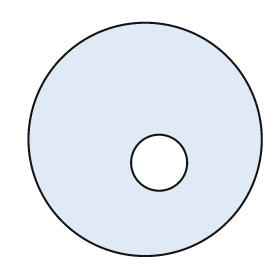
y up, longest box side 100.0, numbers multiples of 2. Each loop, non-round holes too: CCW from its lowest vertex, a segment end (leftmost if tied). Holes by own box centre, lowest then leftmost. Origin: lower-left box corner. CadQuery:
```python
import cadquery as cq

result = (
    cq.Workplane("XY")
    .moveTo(50.0, 50.0)
    .circle(50.0)
    .moveTo(56.0, 40.0)
    .circle(12.0)
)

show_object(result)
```